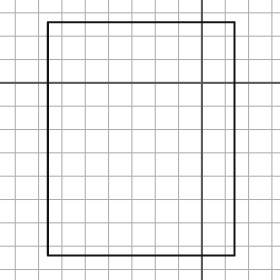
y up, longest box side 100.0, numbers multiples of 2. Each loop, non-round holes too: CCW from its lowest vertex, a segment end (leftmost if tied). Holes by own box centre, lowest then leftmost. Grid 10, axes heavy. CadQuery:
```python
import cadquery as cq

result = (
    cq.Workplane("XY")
    .moveTo(-66.0, -74.0)
    .lineTo(14.0, -74.0)
    .lineTo(14.0, 26.0)
    .lineTo(-66.0, 26.0)
    .close()
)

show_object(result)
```